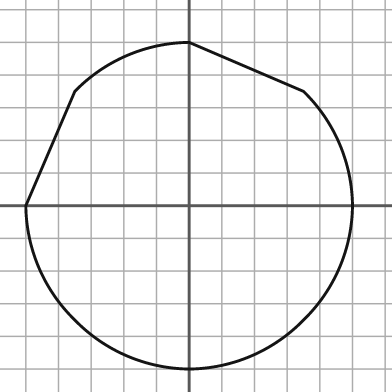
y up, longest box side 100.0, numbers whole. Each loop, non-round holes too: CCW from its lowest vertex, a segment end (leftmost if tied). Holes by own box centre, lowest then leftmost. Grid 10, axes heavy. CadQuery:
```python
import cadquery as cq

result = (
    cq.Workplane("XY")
    .moveTo(0.0, -50.0)
    .threePointArc((19.0, -46.0), (35.0, -35.0))
    .threePointArc((46.0, -19.0), (50.0, 0.0))
    .threePointArc((46.0, 19.0), (35.0, 35.0))
    .lineTo(0.0, 50.0)
    .threePointArc((-19.0, 46.0), (-35.0, 35.0))
    .lineTo(-50.0, 0.0)
    .threePointArc((-46.0, -19.0), (-35.0, -35.0))
    .threePointArc((-19.0, -46.0), (0.0, -50.0))
    .close()
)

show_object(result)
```